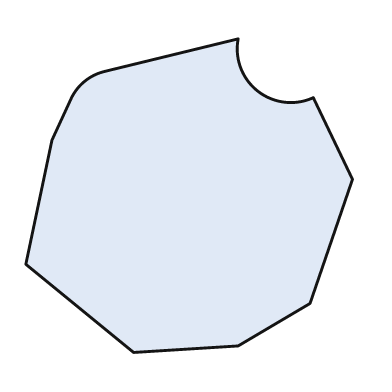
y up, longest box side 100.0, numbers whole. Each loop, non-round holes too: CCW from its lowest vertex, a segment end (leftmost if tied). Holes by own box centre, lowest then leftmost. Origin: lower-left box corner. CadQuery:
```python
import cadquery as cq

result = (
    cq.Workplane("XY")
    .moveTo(33.0, 0.0)
    .lineTo(65.0, 2.0)
    .lineTo(87.0, 15.0)
    .lineTo(100.0, 53.0)
    .lineTo(88.0, 78.0)
    .threePointArc((71.0, 80.0), (65.0, 96.0))
    .lineTo(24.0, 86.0)
    .threePointArc((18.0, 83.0), (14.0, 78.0))
    .lineTo(8.0, 65.0)
    .lineTo(0.0, 27.0)
    .close()
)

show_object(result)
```